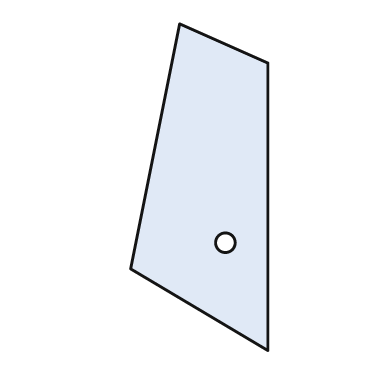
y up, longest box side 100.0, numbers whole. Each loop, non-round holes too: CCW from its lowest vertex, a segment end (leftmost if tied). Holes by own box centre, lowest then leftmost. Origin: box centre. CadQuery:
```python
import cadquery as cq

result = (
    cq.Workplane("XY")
    .moveTo(21.0, -50.0)
    .lineTo(21.0, 38.0)
    .lineTo(-6.0, 50.0)
    .lineTo(-21.0, -25.0)
    .close()
    .moveTo(8.0, -17.0)
    .circle(3.0)
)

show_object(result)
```